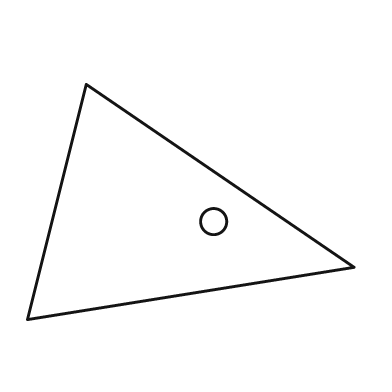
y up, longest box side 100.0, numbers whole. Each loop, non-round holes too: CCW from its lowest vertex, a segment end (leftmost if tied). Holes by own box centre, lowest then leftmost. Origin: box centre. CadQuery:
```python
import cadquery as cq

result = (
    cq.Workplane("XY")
    .moveTo(-50.0, -36.0)
    .lineTo(50.0, -20.0)
    .lineTo(-32.0, 36.0)
    .close()
    .moveTo(7.0, -6.0)
    .circle(4.0)
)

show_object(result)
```